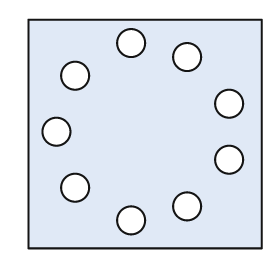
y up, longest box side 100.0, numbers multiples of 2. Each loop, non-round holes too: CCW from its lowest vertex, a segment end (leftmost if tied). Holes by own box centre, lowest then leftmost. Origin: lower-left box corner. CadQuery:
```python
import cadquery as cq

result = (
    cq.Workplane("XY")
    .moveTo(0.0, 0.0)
    .lineTo(100.0, 0.0)
    .lineTo(100.0, 98.0)
    .lineTo(0.0, 98.0)
    .close()
    .moveTo(44.0, 12.0)
    .circle(6.0)
    .moveTo(68.0, 18.0)
    .circle(6.0)
    .moveTo(20.0, 26.0)
    .circle(6.0)
    .moveTo(86.0, 38.0)
    .circle(6.0)
    .moveTo(12.0, 50.0)
    .circle(6.0)
    .moveTo(86.0, 62.0)
    .circle(6.0)
    .moveTo(20.0, 74.0)
    .circle(6.0)
    .moveTo(68.0, 82.0)
    .circle(6.0)
    .moveTo(44.0, 88.0)
    .circle(6.0)
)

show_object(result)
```